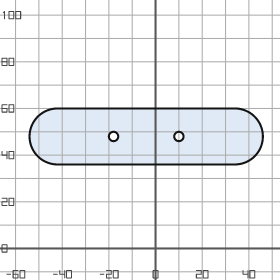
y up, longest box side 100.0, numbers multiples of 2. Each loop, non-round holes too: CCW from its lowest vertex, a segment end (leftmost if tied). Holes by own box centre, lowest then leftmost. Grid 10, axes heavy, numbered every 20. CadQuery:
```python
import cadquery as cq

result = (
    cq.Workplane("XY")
    .moveTo(-42.0, 36.0)
    .lineTo(34.0, 36.0)
    .threePointArc((46.0, 48.0), (34.0, 60.0))
    .lineTo(-42.0, 60.0)
    .threePointArc((-54.0, 48.0), (-42.0, 36.0))
    .close()
    .moveTo(-18.0, 48.0)
    .circle(2.0)
    .moveTo(10.0, 48.0)
    .circle(2.0)
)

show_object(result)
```